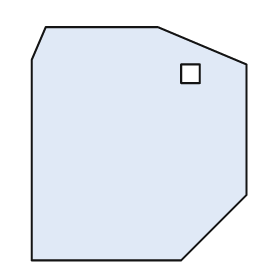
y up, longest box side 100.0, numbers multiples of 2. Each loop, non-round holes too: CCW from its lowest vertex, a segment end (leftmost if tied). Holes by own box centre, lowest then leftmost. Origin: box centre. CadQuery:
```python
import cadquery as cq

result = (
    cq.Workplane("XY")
    .moveTo(-46.0, -50.0)
    .lineTo(18.0, -50.0)
    .lineTo(46.0, -22.0)
    .lineTo(46.0, 34.0)
    .lineTo(8.0, 50.0)
    .lineTo(-40.0, 50.0)
    .lineTo(-46.0, 36.0)
    .close()
    .moveTo(18.0, 26.0)
    .lineTo(26.0, 26.0)
    .lineTo(26.0, 34.0)
    .lineTo(18.0, 34.0)
    .close()
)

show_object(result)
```